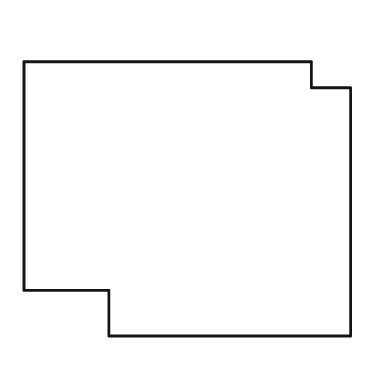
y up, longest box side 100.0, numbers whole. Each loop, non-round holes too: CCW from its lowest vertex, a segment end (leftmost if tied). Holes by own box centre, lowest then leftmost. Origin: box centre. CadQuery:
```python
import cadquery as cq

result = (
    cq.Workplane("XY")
    .moveTo(-24.0, -42.0)
    .lineTo(50.0, -42.0)
    .lineTo(50.0, 34.0)
    .lineTo(38.0, 34.0)
    .lineTo(38.0, 42.0)
    .lineTo(-50.0, 42.0)
    .lineTo(-50.0, -28.0)
    .lineTo(-24.0, -28.0)
    .close()
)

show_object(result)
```